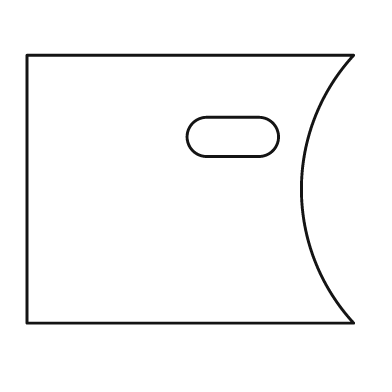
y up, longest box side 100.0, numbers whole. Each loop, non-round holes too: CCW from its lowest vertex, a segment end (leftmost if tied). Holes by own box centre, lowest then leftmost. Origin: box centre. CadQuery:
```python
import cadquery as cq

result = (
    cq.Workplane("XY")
    .moveTo(-50.0, -41.0)
    .lineTo(50.0, -41.0)
    .threePointArc((34.0, 0.0), (50.0, 41.0))
    .lineTo(-50.0, 41.0)
    .close()
    .moveTo(5.0, 10.0)
    .lineTo(21.0, 10.0)
    .threePointArc((27.0, 16.0), (21.0, 22.0))
    .lineTo(5.0, 22.0)
    .threePointArc((-1.0, 16.0), (5.0, 10.0))
    .close()
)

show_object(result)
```